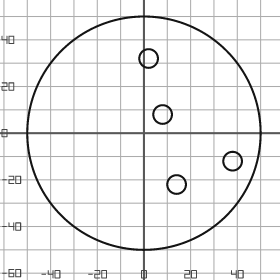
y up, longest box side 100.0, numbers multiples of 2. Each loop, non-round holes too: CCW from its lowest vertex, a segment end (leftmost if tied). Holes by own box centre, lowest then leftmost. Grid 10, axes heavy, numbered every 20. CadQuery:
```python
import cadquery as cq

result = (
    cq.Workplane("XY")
    .moveTo(0.0, 0.0)
    .circle(50.0)
    .moveTo(14.0, -22.0)
    .circle(4.0)
    .moveTo(38.0, -12.0)
    .circle(4.0)
    .moveTo(8.0, 8.0)
    .circle(4.0)
    .moveTo(2.0, 32.0)
    .circle(4.0)
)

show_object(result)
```